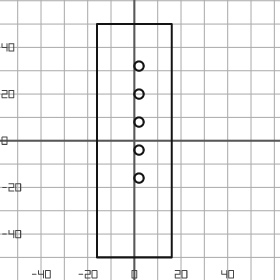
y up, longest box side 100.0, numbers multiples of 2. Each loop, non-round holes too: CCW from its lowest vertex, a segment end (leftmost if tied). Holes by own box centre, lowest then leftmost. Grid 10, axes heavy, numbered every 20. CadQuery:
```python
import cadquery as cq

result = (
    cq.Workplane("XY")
    .moveTo(-16.0, -50.0)
    .lineTo(16.0, -50.0)
    .lineTo(16.0, 50.0)
    .lineTo(-16.0, 50.0)
    .close()
    .moveTo(2.0, -16.0)
    .circle(2.0)
    .moveTo(2.0, -4.0)
    .circle(2.0)
    .moveTo(2.0, 8.0)
    .circle(2.0)
    .moveTo(2.0, 20.0)
    .circle(2.0)
    .moveTo(2.0, 32.0)
    .circle(2.0)
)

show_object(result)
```